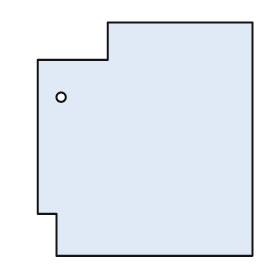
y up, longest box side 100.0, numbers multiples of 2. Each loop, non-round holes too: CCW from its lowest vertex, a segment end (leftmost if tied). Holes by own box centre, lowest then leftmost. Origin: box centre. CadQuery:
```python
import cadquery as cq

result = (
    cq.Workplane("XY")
    .moveTo(-38.0, -50.0)
    .lineTo(46.0, -50.0)
    .lineTo(46.0, 50.0)
    .lineTo(-16.0, 50.0)
    .lineTo(-16.0, 34.0)
    .lineTo(-46.0, 34.0)
    .lineTo(-46.0, -32.0)
    .lineTo(-38.0, -32.0)
    .close()
    .moveTo(-36.0, 18.0)
    .circle(2.0)
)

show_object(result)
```